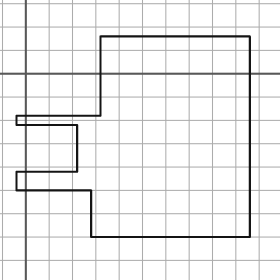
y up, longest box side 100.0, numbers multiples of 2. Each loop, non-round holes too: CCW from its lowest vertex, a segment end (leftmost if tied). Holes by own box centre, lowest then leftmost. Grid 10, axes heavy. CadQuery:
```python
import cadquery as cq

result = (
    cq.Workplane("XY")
    .moveTo(28.0, -70.0)
    .lineTo(96.0, -70.0)
    .lineTo(96.0, 16.0)
    .lineTo(32.0, 16.0)
    .lineTo(32.0, -18.0)
    .lineTo(-4.0, -18.0)
    .lineTo(-4.0, -22.0)
    .lineTo(22.0, -22.0)
    .lineTo(22.0, -42.0)
    .lineTo(-4.0, -42.0)
    .lineTo(-4.0, -50.0)
    .lineTo(28.0, -50.0)
    .close()
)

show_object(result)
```